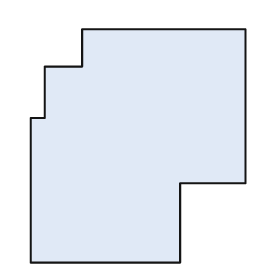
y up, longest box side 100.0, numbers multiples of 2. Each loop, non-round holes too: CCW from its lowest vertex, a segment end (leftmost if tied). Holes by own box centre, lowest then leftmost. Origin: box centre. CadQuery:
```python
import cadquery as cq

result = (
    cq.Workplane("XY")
    .moveTo(-46.0, -50.0)
    .lineTo(18.0, -50.0)
    .lineTo(18.0, -16.0)
    .lineTo(46.0, -16.0)
    .lineTo(46.0, 50.0)
    .lineTo(-24.0, 50.0)
    .lineTo(-24.0, 34.0)
    .lineTo(-40.0, 34.0)
    .lineTo(-40.0, 12.0)
    .lineTo(-46.0, 12.0)
    .close()
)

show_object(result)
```